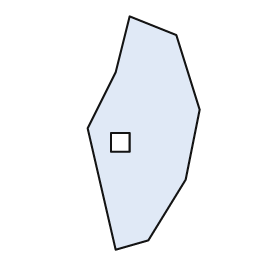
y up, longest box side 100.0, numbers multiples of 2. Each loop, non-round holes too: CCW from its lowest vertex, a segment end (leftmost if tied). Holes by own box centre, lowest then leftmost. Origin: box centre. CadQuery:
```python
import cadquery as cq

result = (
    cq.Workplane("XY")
    .moveTo(-12.0, -50.0)
    .lineTo(2.0, -46.0)
    .lineTo(18.0, -20.0)
    .lineTo(24.0, 10.0)
    .lineTo(14.0, 42.0)
    .lineTo(-6.0, 50.0)
    .lineTo(-12.0, 26.0)
    .lineTo(-24.0, 2.0)
    .close()
    .moveTo(-14.0, -8.0)
    .lineTo(-6.0, -8.0)
    .lineTo(-6.0, 0.0)
    .lineTo(-14.0, 0.0)
    .close()
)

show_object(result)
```